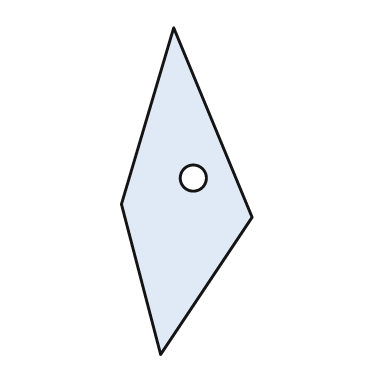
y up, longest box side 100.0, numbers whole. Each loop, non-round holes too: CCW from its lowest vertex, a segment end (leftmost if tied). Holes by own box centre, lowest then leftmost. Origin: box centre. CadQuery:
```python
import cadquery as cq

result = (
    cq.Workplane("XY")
    .moveTo(-8.0, -50.0)
    .lineTo(20.0, -8.0)
    .lineTo(-4.0, 50.0)
    .lineTo(-20.0, -4.0)
    .close()
    .moveTo(2.0, 4.0)
    .circle(4.0)
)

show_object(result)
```